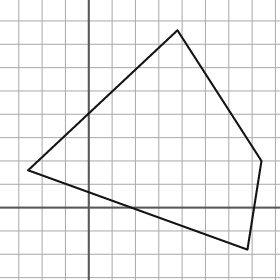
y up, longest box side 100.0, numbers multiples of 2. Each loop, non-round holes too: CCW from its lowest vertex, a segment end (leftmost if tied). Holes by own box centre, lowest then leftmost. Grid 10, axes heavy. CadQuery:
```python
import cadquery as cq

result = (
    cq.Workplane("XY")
    .moveTo(68.0, -18.0)
    .lineTo(74.0, 20.0)
    .lineTo(38.0, 76.0)
    .lineTo(-26.0, 16.0)
    .close()
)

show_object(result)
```